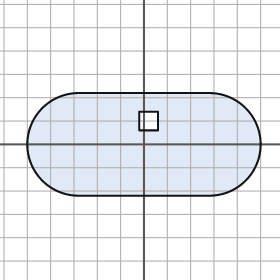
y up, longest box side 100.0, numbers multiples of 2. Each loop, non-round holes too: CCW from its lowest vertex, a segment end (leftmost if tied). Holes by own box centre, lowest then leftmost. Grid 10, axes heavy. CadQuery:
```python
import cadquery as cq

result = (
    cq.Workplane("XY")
    .moveTo(-28.0, -22.0)
    .lineTo(28.0, -22.0)
    .threePointArc((50.0, 0.0), (28.0, 22.0))
    .lineTo(-28.0, 22.0)
    .threePointArc((-50.0, 0.0), (-28.0, -22.0))
    .close()
    .moveTo(-2.0, 6.0)
    .lineTo(6.0, 6.0)
    .lineTo(6.0, 14.0)
    .lineTo(-2.0, 14.0)
    .close()
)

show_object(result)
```